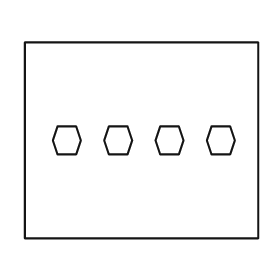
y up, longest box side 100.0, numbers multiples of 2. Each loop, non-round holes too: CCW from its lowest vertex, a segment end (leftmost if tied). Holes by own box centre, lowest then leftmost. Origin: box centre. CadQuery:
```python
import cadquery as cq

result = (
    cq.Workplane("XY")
    .moveTo(-50.0, -42.0)
    .lineTo(50.0, -42.0)
    .lineTo(50.0, 42.0)
    .lineTo(-50.0, 42.0)
    .close()
    .moveTo(-36.0, -6.0)
    .lineTo(-28.0, -6.0)
    .lineTo(-26.0, 0.0)
    .lineTo(-28.0, 6.0)
    .lineTo(-36.0, 6.0)
    .lineTo(-38.0, 0.0)
    .close()
    .moveTo(-14.0, -6.0)
    .lineTo(-6.0, -6.0)
    .lineTo(-4.0, 0.0)
    .lineTo(-6.0, 6.0)
    .lineTo(-14.0, 6.0)
    .lineTo(-16.0, 0.0)
    .close()
    .moveTo(8.0, -6.0)
    .lineTo(16.0, -6.0)
    .lineTo(18.0, 0.0)
    .lineTo(16.0, 6.0)
    .lineTo(8.0, 6.0)
    .lineTo(6.0, 0.0)
    .close()
    .moveTo(30.0, -6.0)
    .lineTo(38.0, -6.0)
    .lineTo(40.0, 0.0)
    .lineTo(38.0, 6.0)
    .lineTo(30.0, 6.0)
    .lineTo(28.0, 0.0)
    .close()
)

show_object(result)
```